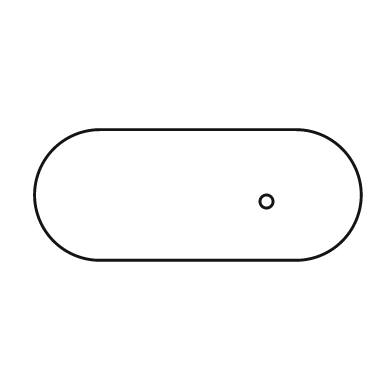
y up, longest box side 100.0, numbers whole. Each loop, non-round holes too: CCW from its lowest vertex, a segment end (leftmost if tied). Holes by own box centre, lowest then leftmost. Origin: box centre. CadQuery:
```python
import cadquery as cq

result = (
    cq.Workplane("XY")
    .moveTo(-30.0, -20.0)
    .lineTo(30.0, -20.0)
    .threePointArc((50.0, 0.0), (30.0, 20.0))
    .lineTo(-30.0, 20.0)
    .threePointArc((-50.0, 0.0), (-30.0, -20.0))
    .close()
    .moveTo(21.0, -2.0)
    .circle(2.0)
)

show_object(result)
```